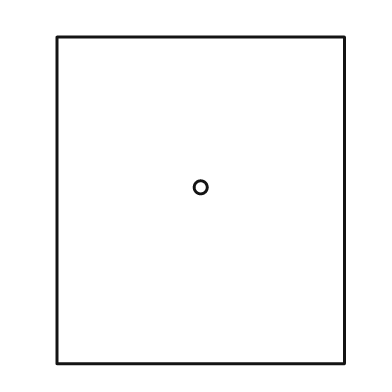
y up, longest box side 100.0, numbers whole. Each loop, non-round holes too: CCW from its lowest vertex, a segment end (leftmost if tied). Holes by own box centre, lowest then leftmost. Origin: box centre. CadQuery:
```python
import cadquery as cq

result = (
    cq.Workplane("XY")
    .moveTo(-44.0, -50.0)
    .lineTo(44.0, -50.0)
    .lineTo(44.0, 50.0)
    .lineTo(-44.0, 50.0)
    .close()
    .moveTo(0.0, 4.0)
    .circle(2.0)
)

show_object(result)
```